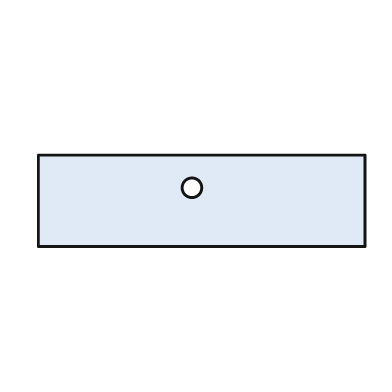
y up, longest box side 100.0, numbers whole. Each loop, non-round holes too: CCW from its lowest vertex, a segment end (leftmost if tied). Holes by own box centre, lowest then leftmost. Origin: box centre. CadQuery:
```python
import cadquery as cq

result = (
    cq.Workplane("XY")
    .moveTo(-50.0, -14.0)
    .lineTo(50.0, -14.0)
    .lineTo(50.0, 14.0)
    .lineTo(-50.0, 14.0)
    .close()
    .moveTo(-3.0, 4.0)
    .circle(3.0)
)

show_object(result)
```